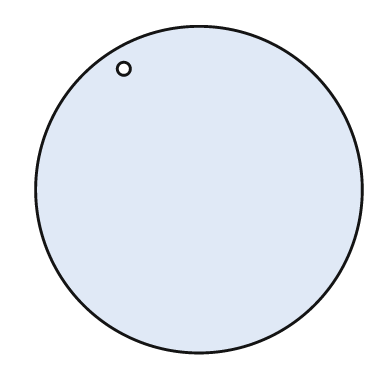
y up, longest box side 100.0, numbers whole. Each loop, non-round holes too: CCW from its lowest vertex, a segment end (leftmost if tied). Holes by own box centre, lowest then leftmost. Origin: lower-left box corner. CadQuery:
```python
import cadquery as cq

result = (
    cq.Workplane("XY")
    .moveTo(50.0, 50.0)
    .circle(50.0)
    .moveTo(27.0, 87.0)
    .circle(2.0)
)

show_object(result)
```